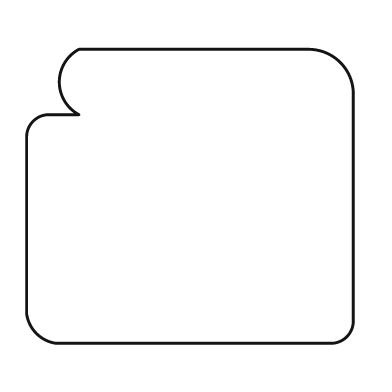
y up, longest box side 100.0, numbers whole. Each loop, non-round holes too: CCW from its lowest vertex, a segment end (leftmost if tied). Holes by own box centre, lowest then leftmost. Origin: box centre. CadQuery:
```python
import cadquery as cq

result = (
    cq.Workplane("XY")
    .moveTo(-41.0, -45.0)
    .lineTo(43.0, -45.0)
    .threePointArc((48.0, -43.0), (50.0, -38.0))
    .lineTo(50.0, 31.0)
    .threePointArc((46.0, 41.0), (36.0, 45.0))
    .lineTo(-34.0, 45.0)
    .threePointArc((-40.0, 35.0), (-34.0, 25.0))
    .lineTo(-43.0, 25.0)
    .threePointArc((-48.0, 23.0), (-50.0, 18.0))
    .lineTo(-50.0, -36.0)
    .threePointArc((-47.0, -42.0), (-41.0, -45.0))
    .close()
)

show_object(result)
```